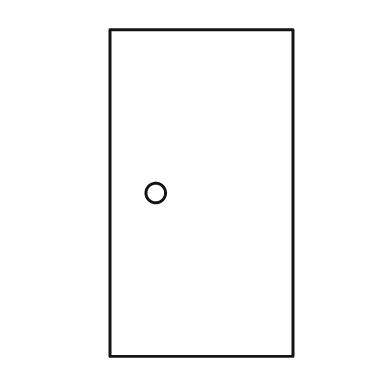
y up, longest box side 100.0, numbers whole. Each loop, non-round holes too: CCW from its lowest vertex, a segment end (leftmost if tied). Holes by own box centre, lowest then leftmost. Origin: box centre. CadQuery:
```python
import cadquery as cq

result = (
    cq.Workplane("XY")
    .moveTo(-28.0, -50.0)
    .lineTo(28.0, -50.0)
    .lineTo(28.0, 50.0)
    .lineTo(-28.0, 50.0)
    .close()
    .moveTo(-14.0, 0.0)
    .circle(3.0)
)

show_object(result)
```